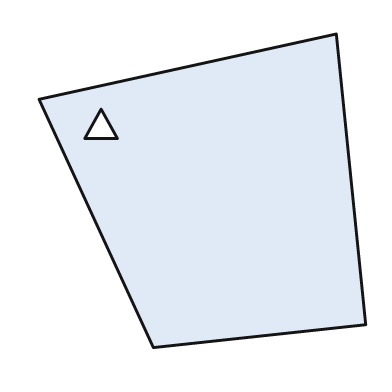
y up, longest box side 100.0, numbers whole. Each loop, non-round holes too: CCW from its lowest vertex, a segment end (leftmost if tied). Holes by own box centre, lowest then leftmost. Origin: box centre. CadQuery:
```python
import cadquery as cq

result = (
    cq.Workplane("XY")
    .moveTo(-15.0, -48.0)
    .lineTo(50.0, -41.0)
    .lineTo(41.0, 48.0)
    .lineTo(-50.0, 28.0)
    .close()
    .moveTo(-36.0, 16.0)
    .lineTo(-26.0, 16.0)
    .lineTo(-31.0, 25.0)
    .close()
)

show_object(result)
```